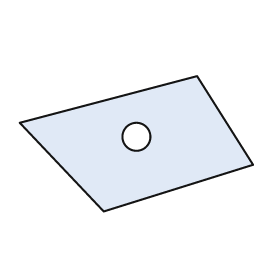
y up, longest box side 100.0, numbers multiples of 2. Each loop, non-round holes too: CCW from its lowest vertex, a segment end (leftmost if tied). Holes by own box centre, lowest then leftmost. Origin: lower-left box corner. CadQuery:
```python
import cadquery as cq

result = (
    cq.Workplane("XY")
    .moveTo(36.0, 0.0)
    .lineTo(100.0, 20.0)
    .lineTo(76.0, 58.0)
    .lineTo(0.0, 38.0)
    .close()
    .moveTo(50.0, 32.0)
    .circle(6.0)
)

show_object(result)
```